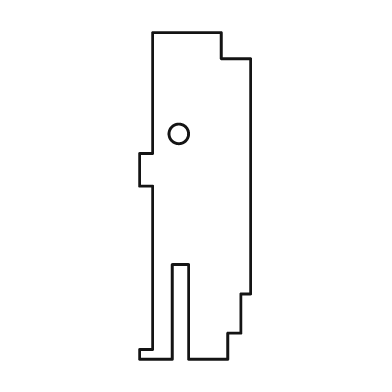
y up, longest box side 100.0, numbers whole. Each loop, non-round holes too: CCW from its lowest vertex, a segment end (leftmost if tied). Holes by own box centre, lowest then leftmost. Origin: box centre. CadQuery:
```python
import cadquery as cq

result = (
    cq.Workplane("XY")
    .moveTo(-17.0, -50.0)
    .lineTo(-7.0, -50.0)
    .lineTo(-7.0, -21.0)
    .lineTo(-2.0, -21.0)
    .lineTo(-2.0, -50.0)
    .lineTo(10.0, -50.0)
    .lineTo(10.0, -42.0)
    .lineTo(14.0, -42.0)
    .lineTo(14.0, -30.0)
    .lineTo(17.0, -30.0)
    .lineTo(17.0, 42.0)
    .lineTo(8.0, 42.0)
    .lineTo(8.0, 50.0)
    .lineTo(-13.0, 50.0)
    .lineTo(-13.0, 13.0)
    .lineTo(-17.0, 13.0)
    .lineTo(-17.0, 3.0)
    .lineTo(-13.0, 3.0)
    .lineTo(-13.0, -47.0)
    .lineTo(-17.0, -47.0)
    .close()
    .moveTo(-5.0, 19.0)
    .circle(3.0)
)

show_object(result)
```